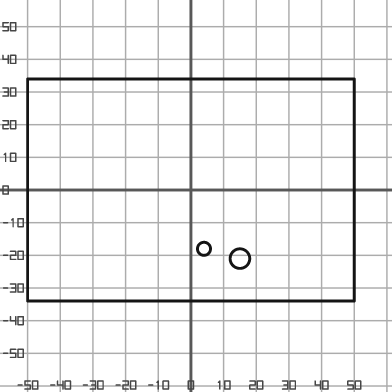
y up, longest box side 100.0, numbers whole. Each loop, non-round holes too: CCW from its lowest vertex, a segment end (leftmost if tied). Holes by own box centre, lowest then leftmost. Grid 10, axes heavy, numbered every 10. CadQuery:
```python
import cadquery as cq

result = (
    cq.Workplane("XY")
    .moveTo(-50.0, -34.0)
    .lineTo(50.0, -34.0)
    .lineTo(50.0, 34.0)
    .lineTo(-50.0, 34.0)
    .close()
    .moveTo(15.0, -21.0)
    .circle(3.0)
    .moveTo(4.0, -18.0)
    .circle(2.0)
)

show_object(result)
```